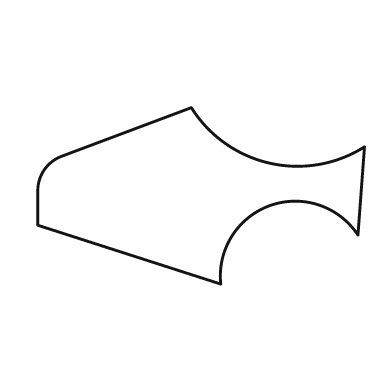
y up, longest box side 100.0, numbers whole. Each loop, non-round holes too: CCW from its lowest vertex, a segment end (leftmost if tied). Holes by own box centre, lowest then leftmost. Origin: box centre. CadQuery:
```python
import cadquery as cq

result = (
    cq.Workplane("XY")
    .moveTo(6.0, -27.0)
    .threePointArc((21.0, -3.0), (48.0, -12.0))
    .lineTo(50.0, 15.0)
    .threePointArc((21.0, 10.0), (-3.0, 27.0))
    .lineTo(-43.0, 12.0)
    .threePointArc((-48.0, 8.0), (-50.0, 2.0))
    .lineTo(-50.0, -9.0)
    .close()
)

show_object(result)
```